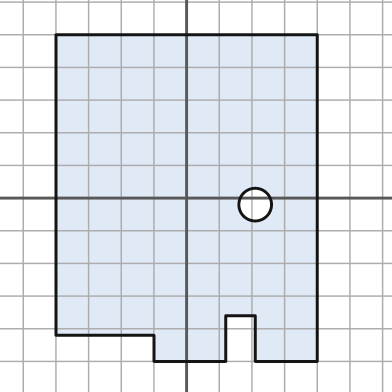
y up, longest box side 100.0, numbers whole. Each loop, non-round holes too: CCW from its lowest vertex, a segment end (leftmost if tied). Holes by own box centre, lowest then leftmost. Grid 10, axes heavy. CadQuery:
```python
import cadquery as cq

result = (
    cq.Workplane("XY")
    .moveTo(-10.0, -50.0)
    .lineTo(12.0, -50.0)
    .lineTo(12.0, -36.0)
    .lineTo(21.0, -36.0)
    .lineTo(21.0, -50.0)
    .lineTo(40.0, -50.0)
    .lineTo(40.0, 50.0)
    .lineTo(-40.0, 50.0)
    .lineTo(-40.0, -42.0)
    .lineTo(-10.0, -42.0)
    .close()
    .moveTo(21.0, -2.0)
    .circle(5.0)
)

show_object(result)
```